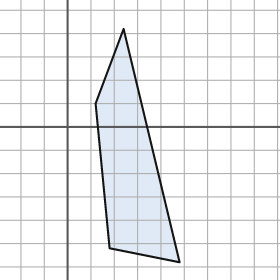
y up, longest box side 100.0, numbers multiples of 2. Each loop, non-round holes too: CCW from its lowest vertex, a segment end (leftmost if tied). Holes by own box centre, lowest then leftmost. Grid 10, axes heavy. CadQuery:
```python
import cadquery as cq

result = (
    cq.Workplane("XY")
    .moveTo(48.0, -58.0)
    .lineTo(24.0, 42.0)
    .lineTo(12.0, 10.0)
    .lineTo(18.0, -52.0)
    .close()
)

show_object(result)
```